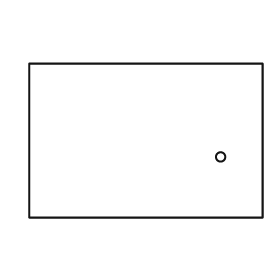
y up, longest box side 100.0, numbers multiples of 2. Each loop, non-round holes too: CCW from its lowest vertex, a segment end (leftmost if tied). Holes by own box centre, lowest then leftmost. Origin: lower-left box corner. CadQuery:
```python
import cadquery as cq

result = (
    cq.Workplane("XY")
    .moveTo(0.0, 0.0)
    .lineTo(100.0, 0.0)
    .lineTo(100.0, 66.0)
    .lineTo(0.0, 66.0)
    .close()
    .moveTo(82.0, 26.0)
    .circle(2.0)
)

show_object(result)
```